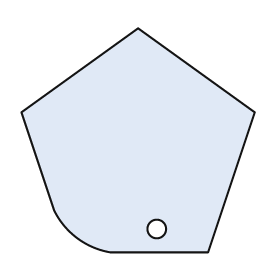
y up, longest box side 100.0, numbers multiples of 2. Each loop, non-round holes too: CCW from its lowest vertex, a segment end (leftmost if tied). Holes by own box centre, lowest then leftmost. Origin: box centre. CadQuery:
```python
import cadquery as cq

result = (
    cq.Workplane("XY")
    .moveTo(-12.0, -48.0)
    .lineTo(30.0, -48.0)
    .lineTo(50.0, 12.0)
    .lineTo(0.0, 48.0)
    .lineTo(-50.0, 12.0)
    .lineTo(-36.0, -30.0)
    .threePointArc((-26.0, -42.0), (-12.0, -48.0))
    .close()
    .moveTo(8.0, -38.0)
    .circle(4.0)
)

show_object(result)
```